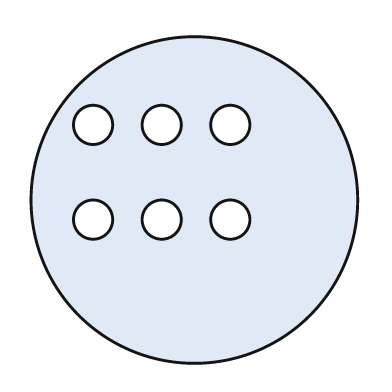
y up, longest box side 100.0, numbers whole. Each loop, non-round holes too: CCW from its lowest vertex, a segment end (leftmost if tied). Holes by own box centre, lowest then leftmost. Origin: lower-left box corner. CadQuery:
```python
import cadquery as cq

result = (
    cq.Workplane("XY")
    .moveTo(50.0, 50.0)
    .circle(50.0)
    .moveTo(19.0, 44.0)
    .circle(6.0)
    .moveTo(40.0, 44.0)
    .circle(6.0)
    .moveTo(61.0, 44.0)
    .circle(6.0)
    .moveTo(19.0, 73.0)
    .circle(6.0)
    .moveTo(40.0, 73.0)
    .circle(6.0)
    .moveTo(61.0, 73.0)
    .circle(6.0)
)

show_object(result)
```